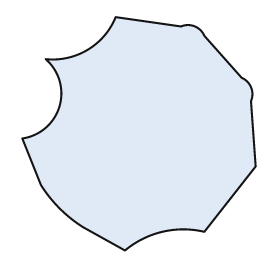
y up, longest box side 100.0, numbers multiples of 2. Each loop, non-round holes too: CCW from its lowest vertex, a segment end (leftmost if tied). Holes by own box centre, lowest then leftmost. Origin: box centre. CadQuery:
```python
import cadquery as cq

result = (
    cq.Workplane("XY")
    .moveTo(-6.0, -50.0)
    .threePointArc((10.0, -42.0), (28.0, -42.0))
    .lineTo(50.0, -14.0)
    .lineTo(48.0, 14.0)
    .threePointArc((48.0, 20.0), (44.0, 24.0))
    .lineTo(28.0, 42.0)
    .threePointArc((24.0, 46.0), (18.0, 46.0))
    .lineTo(-10.0, 50.0)
    .threePointArc((-22.0, 36.0), (-40.0, 32.0))
    .threePointArc((-34.0, 12.0), (-50.0, -2.0))
    .lineTo(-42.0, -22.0)
    .threePointArc((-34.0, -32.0), (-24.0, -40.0))
    .close()
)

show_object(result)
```